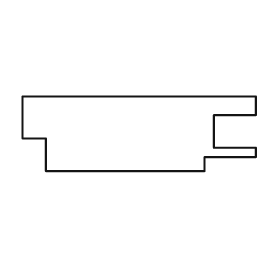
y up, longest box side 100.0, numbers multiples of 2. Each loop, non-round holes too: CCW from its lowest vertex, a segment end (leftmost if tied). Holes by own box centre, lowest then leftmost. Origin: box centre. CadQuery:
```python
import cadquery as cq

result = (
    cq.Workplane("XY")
    .moveTo(-40.0, -16.0)
    .lineTo(28.0, -16.0)
    .lineTo(28.0, -10.0)
    .lineTo(50.0, -10.0)
    .lineTo(50.0, -6.0)
    .lineTo(32.0, -6.0)
    .lineTo(32.0, 8.0)
    .lineTo(50.0, 8.0)
    .lineTo(50.0, 16.0)
    .lineTo(-50.0, 16.0)
    .lineTo(-50.0, -2.0)
    .lineTo(-40.0, -2.0)
    .close()
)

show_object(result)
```